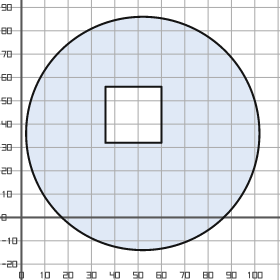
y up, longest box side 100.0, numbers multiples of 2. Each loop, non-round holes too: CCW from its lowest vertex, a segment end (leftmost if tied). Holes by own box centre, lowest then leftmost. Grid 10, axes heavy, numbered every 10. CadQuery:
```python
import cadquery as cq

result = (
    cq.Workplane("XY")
    .moveTo(52.0, 36.0)
    .circle(50.0)
    .moveTo(36.0, 32.0)
    .lineTo(60.0, 32.0)
    .lineTo(60.0, 56.0)
    .lineTo(36.0, 56.0)
    .close()
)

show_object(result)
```